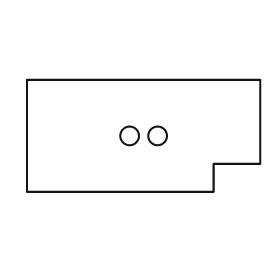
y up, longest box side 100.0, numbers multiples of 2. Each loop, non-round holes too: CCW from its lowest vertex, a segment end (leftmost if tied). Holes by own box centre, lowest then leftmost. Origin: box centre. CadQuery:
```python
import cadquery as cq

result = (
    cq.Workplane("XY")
    .moveTo(-50.0, -24.0)
    .lineTo(30.0, -24.0)
    .lineTo(30.0, -12.0)
    .lineTo(50.0, -12.0)
    .lineTo(50.0, 24.0)
    .lineTo(-50.0, 24.0)
    .close()
    .moveTo(-6.0, 0.0)
    .circle(4.0)
    .moveTo(6.0, 0.0)
    .circle(4.0)
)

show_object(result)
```